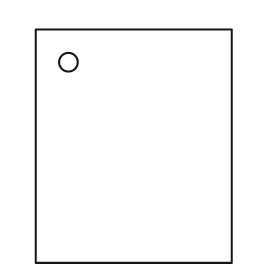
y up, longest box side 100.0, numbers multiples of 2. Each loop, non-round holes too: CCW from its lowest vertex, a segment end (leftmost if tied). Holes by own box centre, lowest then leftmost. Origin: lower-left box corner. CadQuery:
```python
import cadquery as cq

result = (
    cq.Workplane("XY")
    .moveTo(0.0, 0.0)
    .lineTo(84.0, 0.0)
    .lineTo(84.0, 100.0)
    .lineTo(0.0, 100.0)
    .close()
    .moveTo(14.0, 86.0)
    .circle(4.0)
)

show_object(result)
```